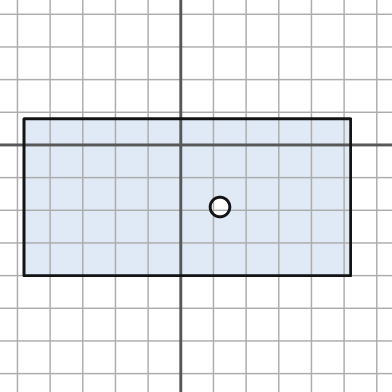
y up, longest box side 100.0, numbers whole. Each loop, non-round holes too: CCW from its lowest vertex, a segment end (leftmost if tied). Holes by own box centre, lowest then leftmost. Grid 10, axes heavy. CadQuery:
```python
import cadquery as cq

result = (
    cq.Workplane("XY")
    .moveTo(-48.0, -40.0)
    .lineTo(52.0, -40.0)
    .lineTo(52.0, 8.0)
    .lineTo(-48.0, 8.0)
    .close()
    .moveTo(12.0, -19.0)
    .circle(3.0)
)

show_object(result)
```